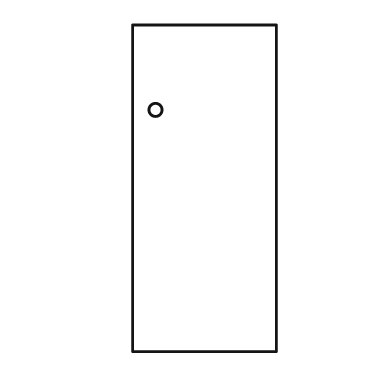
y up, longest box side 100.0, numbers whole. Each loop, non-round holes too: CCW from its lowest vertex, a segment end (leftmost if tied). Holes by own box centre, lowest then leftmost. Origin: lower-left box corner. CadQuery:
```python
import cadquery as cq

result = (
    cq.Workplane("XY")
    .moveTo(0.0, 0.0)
    .lineTo(44.0, 0.0)
    .lineTo(44.0, 100.0)
    .lineTo(0.0, 100.0)
    .close()
    .moveTo(7.0, 74.0)
    .circle(2.0)
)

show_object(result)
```